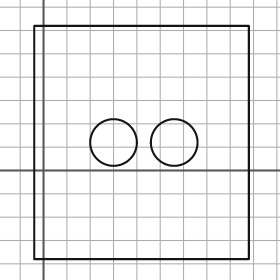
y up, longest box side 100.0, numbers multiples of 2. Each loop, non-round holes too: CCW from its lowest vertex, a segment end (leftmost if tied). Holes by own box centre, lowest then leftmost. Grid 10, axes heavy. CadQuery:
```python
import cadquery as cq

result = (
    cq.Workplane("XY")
    .moveTo(-4.0, -38.0)
    .lineTo(88.0, -38.0)
    .lineTo(88.0, 62.0)
    .lineTo(-4.0, 62.0)
    .close()
    .moveTo(30.0, 12.0)
    .circle(10.0)
    .moveTo(56.0, 12.0)
    .circle(10.0)
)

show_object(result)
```